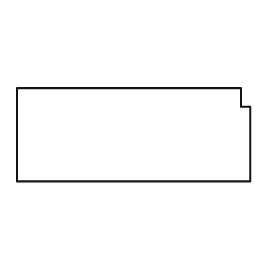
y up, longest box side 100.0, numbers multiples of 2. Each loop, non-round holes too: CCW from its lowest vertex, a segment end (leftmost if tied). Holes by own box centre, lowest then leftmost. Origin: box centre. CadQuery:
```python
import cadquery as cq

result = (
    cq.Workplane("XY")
    .moveTo(-50.0, -20.0)
    .lineTo(50.0, -20.0)
    .lineTo(50.0, 12.0)
    .lineTo(46.0, 12.0)
    .lineTo(46.0, 20.0)
    .lineTo(-50.0, 20.0)
    .close()
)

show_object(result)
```